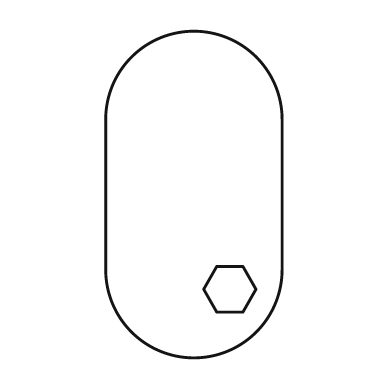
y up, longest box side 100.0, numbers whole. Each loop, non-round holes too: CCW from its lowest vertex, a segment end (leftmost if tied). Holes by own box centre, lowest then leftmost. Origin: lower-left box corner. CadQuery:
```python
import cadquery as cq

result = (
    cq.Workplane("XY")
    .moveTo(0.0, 27.0)
    .threePointArc((27.0, 0.0), (54.0, 27.0))
    .lineTo(54.0, 73.0)
    .threePointArc((27.0, 100.0), (0.0, 73.0))
    .close()
    .moveTo(34.0, 14.0)
    .lineTo(42.0, 14.0)
    .lineTo(46.0, 21.0)
    .lineTo(42.0, 28.0)
    .lineTo(34.0, 28.0)
    .lineTo(30.0, 21.0)
    .close()
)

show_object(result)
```